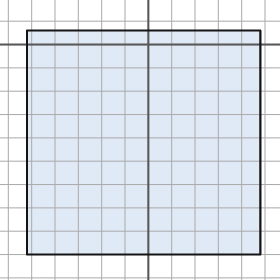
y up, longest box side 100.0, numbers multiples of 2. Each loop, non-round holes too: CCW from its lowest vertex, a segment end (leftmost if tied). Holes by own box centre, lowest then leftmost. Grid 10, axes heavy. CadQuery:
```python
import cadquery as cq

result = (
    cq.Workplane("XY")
    .moveTo(-52.0, -90.0)
    .lineTo(48.0, -90.0)
    .lineTo(48.0, 6.0)
    .lineTo(-52.0, 6.0)
    .close()
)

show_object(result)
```